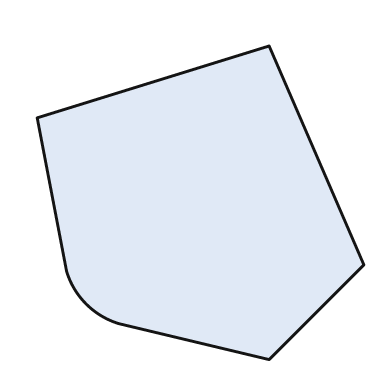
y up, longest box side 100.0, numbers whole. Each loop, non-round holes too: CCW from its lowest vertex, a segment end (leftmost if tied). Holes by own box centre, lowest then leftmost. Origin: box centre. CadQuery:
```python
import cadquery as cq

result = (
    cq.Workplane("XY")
    .moveTo(21.0, -48.0)
    .lineTo(50.0, -19.0)
    .lineTo(21.0, 48.0)
    .lineTo(-50.0, 26.0)
    .lineTo(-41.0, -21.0)
    .threePointArc((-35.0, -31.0), (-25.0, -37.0))
    .close()
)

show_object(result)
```